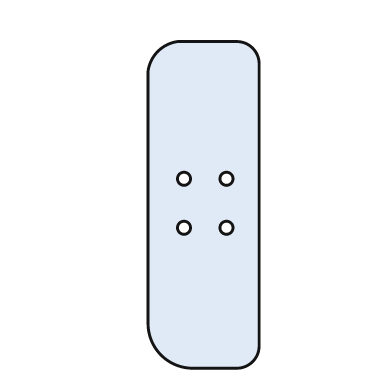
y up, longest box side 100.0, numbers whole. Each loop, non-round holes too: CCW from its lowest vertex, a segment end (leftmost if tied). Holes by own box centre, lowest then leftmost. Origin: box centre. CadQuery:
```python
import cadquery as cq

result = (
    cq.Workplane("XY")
    .moveTo(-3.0, -50.0)
    .lineTo(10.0, -50.0)
    .threePointArc((15.0, -48.0), (17.0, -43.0))
    .lineTo(17.0, 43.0)
    .threePointArc((15.0, 48.0), (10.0, 50.0))
    .lineTo(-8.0, 50.0)
    .threePointArc((-14.0, 47.0), (-17.0, 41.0))
    .lineTo(-17.0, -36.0)
    .threePointArc((-13.0, -46.0), (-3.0, -50.0))
    .close()
    .moveTo(-6.0, -7.0)
    .circle(2.0)
    .moveTo(7.0, -7.0)
    .circle(2.0)
    .moveTo(-6.0, 8.0)
    .circle(2.0)
    .moveTo(7.0, 8.0)
    .circle(2.0)
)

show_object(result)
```